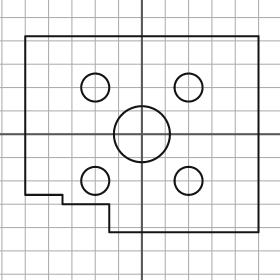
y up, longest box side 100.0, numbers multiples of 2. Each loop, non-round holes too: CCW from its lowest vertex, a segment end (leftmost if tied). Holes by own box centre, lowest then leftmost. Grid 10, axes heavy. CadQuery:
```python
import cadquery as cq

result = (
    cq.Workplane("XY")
    .moveTo(-14.0, -42.0)
    .lineTo(50.0, -42.0)
    .lineTo(50.0, 42.0)
    .lineTo(-50.0, 42.0)
    .lineTo(-50.0, -26.0)
    .lineTo(-34.0, -26.0)
    .lineTo(-34.0, -30.0)
    .lineTo(-14.0, -30.0)
    .close()
    .moveTo(-20.0, -20.0)
    .circle(6.0)
    .moveTo(20.0, -20.0)
    .circle(6.0)
    .moveTo(0.0, 0.0)
    .circle(12.0)
    .moveTo(-20.0, 20.0)
    .circle(6.0)
    .moveTo(20.0, 20.0)
    .circle(6.0)
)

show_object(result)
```